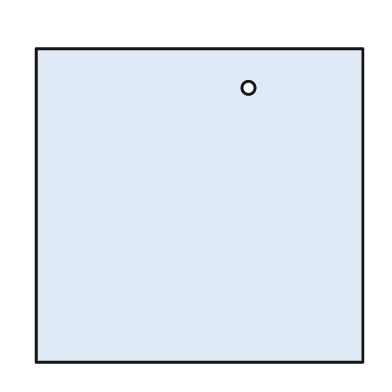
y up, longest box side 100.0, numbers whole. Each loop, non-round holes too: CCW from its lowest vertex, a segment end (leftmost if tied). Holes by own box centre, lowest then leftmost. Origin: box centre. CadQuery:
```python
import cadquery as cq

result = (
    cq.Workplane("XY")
    .moveTo(-50.0, -48.0)
    .lineTo(50.0, -48.0)
    .lineTo(50.0, 48.0)
    .lineTo(-50.0, 48.0)
    .close()
    .moveTo(15.0, 36.0)
    .circle(2.0)
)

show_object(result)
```